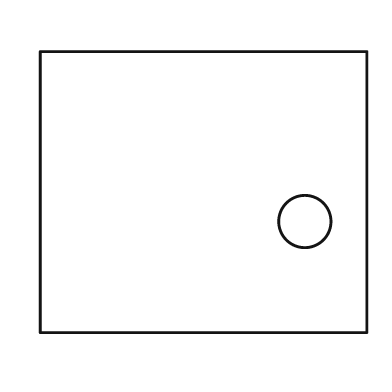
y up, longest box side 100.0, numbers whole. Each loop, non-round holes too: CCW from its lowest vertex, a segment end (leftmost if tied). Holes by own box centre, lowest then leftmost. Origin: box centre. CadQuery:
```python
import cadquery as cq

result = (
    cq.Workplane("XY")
    .moveTo(-50.0, -43.0)
    .lineTo(50.0, -43.0)
    .lineTo(50.0, 43.0)
    .lineTo(-50.0, 43.0)
    .close()
    .moveTo(31.0, -9.0)
    .circle(8.0)
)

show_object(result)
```